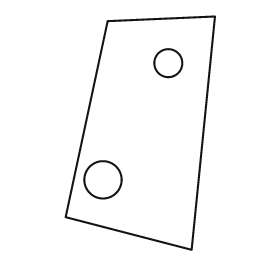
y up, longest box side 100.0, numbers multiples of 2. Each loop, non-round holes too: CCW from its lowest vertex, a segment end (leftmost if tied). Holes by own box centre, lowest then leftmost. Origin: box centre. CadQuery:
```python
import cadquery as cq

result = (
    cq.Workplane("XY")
    .moveTo(22.0, -50.0)
    .lineTo(32.0, 50.0)
    .lineTo(-14.0, 48.0)
    .lineTo(-32.0, -36.0)
    .close()
    .moveTo(-16.0, -20.0)
    .circle(8.0)
    .moveTo(12.0, 30.0)
    .circle(6.0)
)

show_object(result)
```